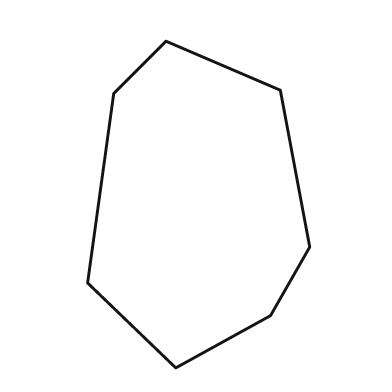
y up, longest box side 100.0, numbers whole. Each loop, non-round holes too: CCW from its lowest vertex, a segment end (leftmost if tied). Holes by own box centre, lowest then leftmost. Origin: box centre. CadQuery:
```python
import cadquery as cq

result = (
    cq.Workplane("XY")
    .moveTo(-7.0, -50.0)
    .lineTo(22.0, -34.0)
    .lineTo(34.0, -13.0)
    .lineTo(25.0, 35.0)
    .lineTo(-10.0, 50.0)
    .lineTo(-26.0, 34.0)
    .lineTo(-34.0, -24.0)
    .close()
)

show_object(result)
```